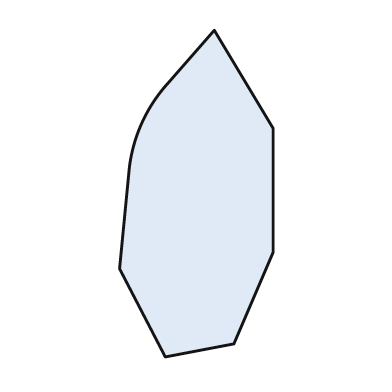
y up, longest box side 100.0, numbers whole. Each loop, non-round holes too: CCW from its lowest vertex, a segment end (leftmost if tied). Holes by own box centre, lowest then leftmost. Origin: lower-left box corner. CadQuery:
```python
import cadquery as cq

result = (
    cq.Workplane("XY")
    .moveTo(14.0, 0.0)
    .lineTo(35.0, 4.0)
    .lineTo(47.0, 32.0)
    .lineTo(47.0, 70.0)
    .lineTo(29.0, 100.0)
    .lineTo(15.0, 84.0)
    .threePointArc((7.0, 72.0), (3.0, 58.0))
    .lineTo(0.0, 27.0)
    .close()
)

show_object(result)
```